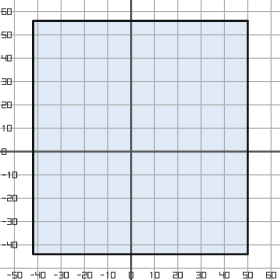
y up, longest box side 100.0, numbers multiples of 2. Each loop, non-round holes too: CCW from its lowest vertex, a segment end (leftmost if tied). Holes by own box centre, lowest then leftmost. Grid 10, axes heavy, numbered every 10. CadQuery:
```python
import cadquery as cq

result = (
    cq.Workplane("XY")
    .moveTo(-42.0, -44.0)
    .lineTo(50.0, -44.0)
    .lineTo(50.0, 56.0)
    .lineTo(-42.0, 56.0)
    .close()
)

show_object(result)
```